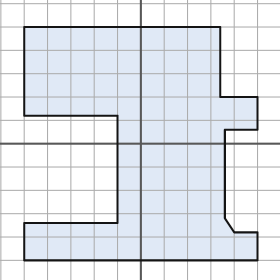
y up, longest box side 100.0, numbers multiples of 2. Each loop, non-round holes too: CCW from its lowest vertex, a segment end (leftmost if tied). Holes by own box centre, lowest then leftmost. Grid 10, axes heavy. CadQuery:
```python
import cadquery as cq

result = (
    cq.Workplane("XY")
    .moveTo(-50.0, -50.0)
    .lineTo(50.0, -50.0)
    .lineTo(50.0, -38.0)
    .lineTo(40.0, -38.0)
    .lineTo(36.0, -32.0)
    .lineTo(36.0, 6.0)
    .lineTo(50.0, 6.0)
    .lineTo(50.0, 20.0)
    .lineTo(34.0, 20.0)
    .lineTo(34.0, 50.0)
    .lineTo(-50.0, 50.0)
    .lineTo(-50.0, 12.0)
    .lineTo(-10.0, 12.0)
    .lineTo(-10.0, -34.0)
    .lineTo(-50.0, -34.0)
    .close()
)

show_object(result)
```